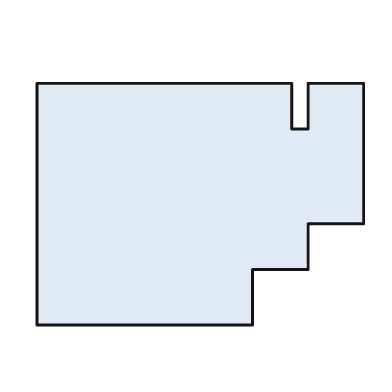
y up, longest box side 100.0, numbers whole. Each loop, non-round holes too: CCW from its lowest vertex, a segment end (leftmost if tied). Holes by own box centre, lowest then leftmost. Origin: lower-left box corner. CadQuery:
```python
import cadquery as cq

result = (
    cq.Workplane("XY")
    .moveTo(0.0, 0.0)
    .lineTo(66.0, 0.0)
    .lineTo(66.0, 17.0)
    .lineTo(83.0, 17.0)
    .lineTo(83.0, 31.0)
    .lineTo(100.0, 31.0)
    .lineTo(100.0, 74.0)
    .lineTo(83.0, 74.0)
    .lineTo(83.0, 60.0)
    .lineTo(78.0, 60.0)
    .lineTo(78.0, 74.0)
    .lineTo(0.0, 74.0)
    .close()
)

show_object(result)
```